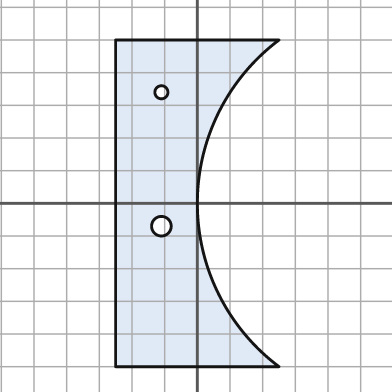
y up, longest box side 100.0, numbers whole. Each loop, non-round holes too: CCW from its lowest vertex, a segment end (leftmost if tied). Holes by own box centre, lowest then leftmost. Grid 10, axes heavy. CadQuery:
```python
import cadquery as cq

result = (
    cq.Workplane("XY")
    .moveTo(-25.0, -50.0)
    .lineTo(25.0, -50.0)
    .threePointArc((0.0, 0.0), (25.0, 50.0))
    .lineTo(-25.0, 50.0)
    .close()
    .moveTo(-11.0, -7.0)
    .circle(3.0)
    .moveTo(-11.0, 34.0)
    .circle(2.0)
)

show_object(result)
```